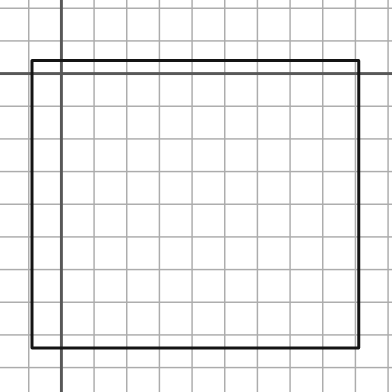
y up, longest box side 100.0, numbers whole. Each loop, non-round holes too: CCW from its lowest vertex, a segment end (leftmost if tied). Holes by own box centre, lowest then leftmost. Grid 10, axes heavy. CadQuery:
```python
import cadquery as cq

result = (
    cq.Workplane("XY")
    .moveTo(-9.0, -84.0)
    .lineTo(91.0, -84.0)
    .lineTo(91.0, 4.0)
    .lineTo(-9.0, 4.0)
    .close()
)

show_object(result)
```